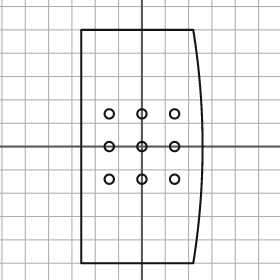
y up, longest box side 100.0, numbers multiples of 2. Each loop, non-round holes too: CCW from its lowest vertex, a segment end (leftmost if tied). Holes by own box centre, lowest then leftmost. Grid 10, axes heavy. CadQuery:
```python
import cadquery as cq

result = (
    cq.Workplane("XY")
    .moveTo(-26.0, -50.0)
    .lineTo(22.0, -50.0)
    .threePointArc((26.0, 0.0), (22.0, 50.0))
    .lineTo(-26.0, 50.0)
    .close()
    .moveTo(-14.0, -14.0)
    .circle(2.0)
    .moveTo(0.0, -14.0)
    .circle(2.0)
    .moveTo(14.0, -14.0)
    .circle(2.0)
    .moveTo(-14.0, 0.0)
    .circle(2.0)
    .moveTo(0.0, 0.0)
    .circle(2.0)
    .moveTo(14.0, 0.0)
    .circle(2.0)
    .moveTo(-14.0, 14.0)
    .circle(2.0)
    .moveTo(0.0, 14.0)
    .circle(2.0)
    .moveTo(14.0, 14.0)
    .circle(2.0)
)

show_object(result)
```